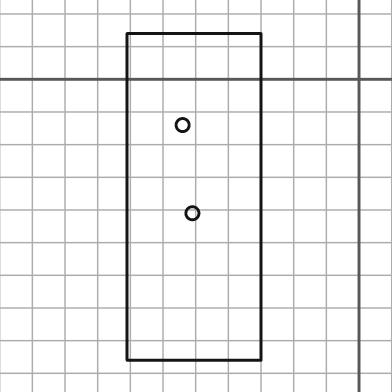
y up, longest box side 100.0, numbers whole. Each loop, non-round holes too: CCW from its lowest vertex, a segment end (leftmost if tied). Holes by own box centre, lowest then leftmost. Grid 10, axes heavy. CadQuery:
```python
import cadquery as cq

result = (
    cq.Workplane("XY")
    .moveTo(-71.0, -86.0)
    .lineTo(-30.0, -86.0)
    .lineTo(-30.0, 14.0)
    .lineTo(-71.0, 14.0)
    .close()
    .moveTo(-51.0, -41.0)
    .circle(2.0)
    .moveTo(-54.0, -14.0)
    .circle(2.0)
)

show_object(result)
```